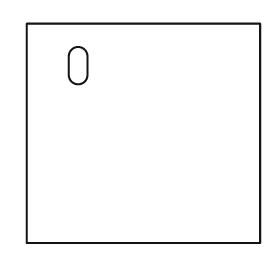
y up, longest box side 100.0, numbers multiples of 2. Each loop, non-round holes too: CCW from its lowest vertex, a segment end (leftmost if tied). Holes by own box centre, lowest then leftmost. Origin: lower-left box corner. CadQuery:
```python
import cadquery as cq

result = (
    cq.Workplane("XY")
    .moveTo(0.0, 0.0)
    .lineTo(100.0, 0.0)
    .lineTo(100.0, 94.0)
    .lineTo(0.0, 94.0)
    .close()
    .moveTo(18.0, 72.0)
    .threePointArc((22.0, 68.0), (26.0, 72.0))
    .lineTo(26.0, 80.0)
    .threePointArc((22.0, 84.0), (18.0, 80.0))
    .close()
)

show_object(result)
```